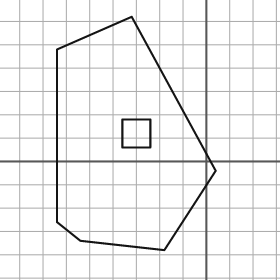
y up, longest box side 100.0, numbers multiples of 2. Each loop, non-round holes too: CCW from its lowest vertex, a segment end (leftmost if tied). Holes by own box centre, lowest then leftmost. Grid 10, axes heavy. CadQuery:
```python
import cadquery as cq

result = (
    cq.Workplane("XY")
    .moveTo(-18.0, -38.0)
    .lineTo(4.0, -4.0)
    .lineTo(-32.0, 62.0)
    .lineTo(-64.0, 48.0)
    .lineTo(-64.0, -26.0)
    .lineTo(-54.0, -34.0)
    .close()
    .moveTo(-36.0, 6.0)
    .lineTo(-24.0, 6.0)
    .lineTo(-24.0, 18.0)
    .lineTo(-36.0, 18.0)
    .close()
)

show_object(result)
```